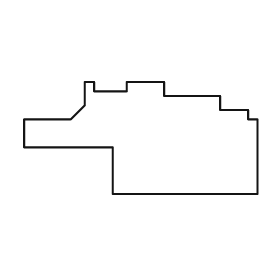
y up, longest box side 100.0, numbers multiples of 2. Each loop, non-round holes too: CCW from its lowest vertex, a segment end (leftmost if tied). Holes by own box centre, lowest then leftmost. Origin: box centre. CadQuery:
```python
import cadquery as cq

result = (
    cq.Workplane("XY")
    .moveTo(-12.0, -24.0)
    .lineTo(50.0, -24.0)
    .lineTo(50.0, 8.0)
    .lineTo(46.0, 8.0)
    .lineTo(46.0, 12.0)
    .lineTo(34.0, 12.0)
    .lineTo(34.0, 18.0)
    .lineTo(10.0, 18.0)
    .lineTo(10.0, 24.0)
    .lineTo(-6.0, 24.0)
    .lineTo(-6.0, 20.0)
    .lineTo(-20.0, 20.0)
    .lineTo(-20.0, 24.0)
    .lineTo(-24.0, 24.0)
    .lineTo(-24.0, 14.0)
    .lineTo(-30.0, 8.0)
    .lineTo(-50.0, 8.0)
    .lineTo(-50.0, -4.0)
    .lineTo(-12.0, -4.0)
    .close()
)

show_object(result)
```